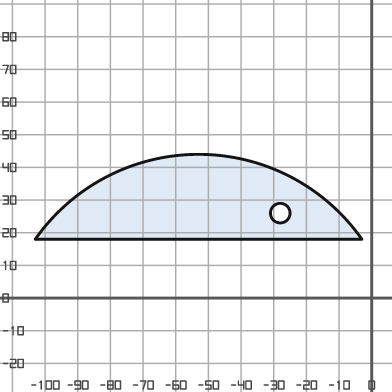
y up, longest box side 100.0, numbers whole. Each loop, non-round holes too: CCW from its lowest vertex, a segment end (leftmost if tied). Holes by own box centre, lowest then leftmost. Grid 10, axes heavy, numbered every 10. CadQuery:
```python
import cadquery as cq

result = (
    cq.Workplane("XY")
    .moveTo(-103.0, 18.0)
    .lineTo(-3.0, 18.0)
    .threePointArc((-53.0, 44.0), (-103.0, 18.0))
    .close()
    .moveTo(-28.0, 26.0)
    .circle(3.0)
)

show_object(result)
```